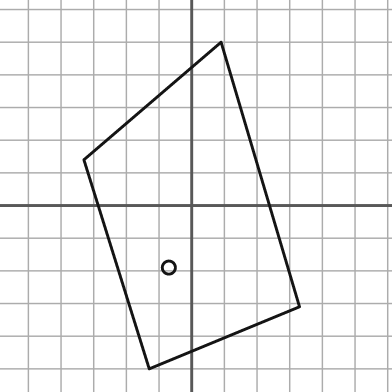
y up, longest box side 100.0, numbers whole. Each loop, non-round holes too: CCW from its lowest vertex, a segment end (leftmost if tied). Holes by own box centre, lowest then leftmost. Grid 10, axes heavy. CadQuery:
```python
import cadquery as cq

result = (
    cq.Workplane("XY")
    .moveTo(-13.0, -50.0)
    .lineTo(33.0, -31.0)
    .lineTo(9.0, 50.0)
    .lineTo(-33.0, 14.0)
    .close()
    .moveTo(-7.0, -19.0)
    .circle(2.0)
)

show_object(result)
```